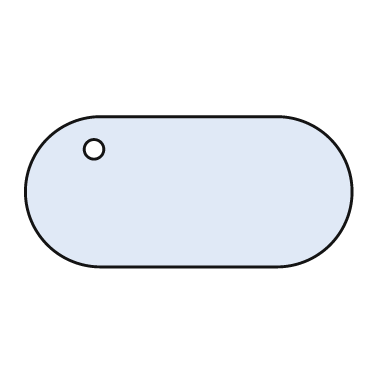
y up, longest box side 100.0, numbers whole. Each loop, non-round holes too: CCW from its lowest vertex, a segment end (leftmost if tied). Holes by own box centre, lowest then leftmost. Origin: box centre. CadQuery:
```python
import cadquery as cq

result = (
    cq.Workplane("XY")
    .moveTo(-27.0, -23.0)
    .lineTo(27.0, -23.0)
    .threePointArc((50.0, 0.0), (27.0, 23.0))
    .lineTo(-27.0, 23.0)
    .threePointArc((-50.0, 0.0), (-27.0, -23.0))
    .close()
    .moveTo(-29.0, 13.0)
    .circle(3.0)
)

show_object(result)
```